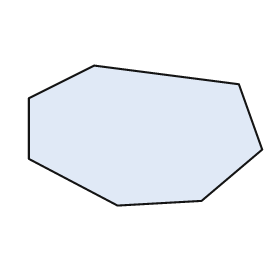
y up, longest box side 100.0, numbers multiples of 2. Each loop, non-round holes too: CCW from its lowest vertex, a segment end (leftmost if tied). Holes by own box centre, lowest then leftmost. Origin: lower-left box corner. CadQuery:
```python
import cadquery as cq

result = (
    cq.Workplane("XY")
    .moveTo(38.0, 0.0)
    .lineTo(74.0, 2.0)
    .lineTo(100.0, 24.0)
    .lineTo(90.0, 52.0)
    .lineTo(28.0, 60.0)
    .lineTo(0.0, 46.0)
    .lineTo(0.0, 20.0)
    .close()
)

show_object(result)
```